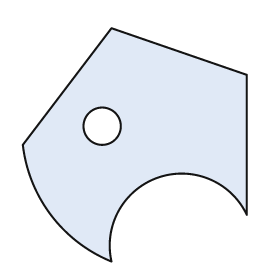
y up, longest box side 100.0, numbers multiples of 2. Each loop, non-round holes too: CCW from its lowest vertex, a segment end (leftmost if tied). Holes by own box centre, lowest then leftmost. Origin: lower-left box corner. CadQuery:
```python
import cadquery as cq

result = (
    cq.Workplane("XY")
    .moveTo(38.0, 0.0)
    .threePointArc((58.0, 36.0), (96.0, 20.0))
    .lineTo(96.0, 80.0)
    .lineTo(38.0, 100.0)
    .lineTo(0.0, 50.0)
    .threePointArc((12.0, 20.0), (38.0, 0.0))
    .close()
    .moveTo(34.0, 58.0)
    .circle(8.0)
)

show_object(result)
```